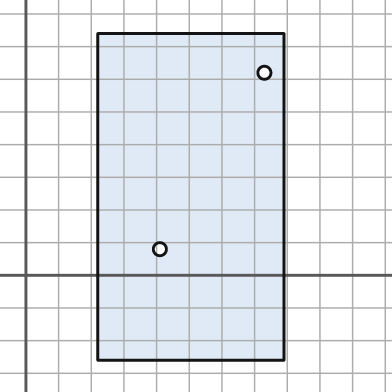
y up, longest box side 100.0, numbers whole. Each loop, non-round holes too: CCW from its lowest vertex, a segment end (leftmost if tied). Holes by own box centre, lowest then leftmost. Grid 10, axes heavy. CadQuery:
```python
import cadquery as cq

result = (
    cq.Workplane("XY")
    .moveTo(22.0, -26.0)
    .lineTo(79.0, -26.0)
    .lineTo(79.0, 74.0)
    .lineTo(22.0, 74.0)
    .close()
    .moveTo(41.0, 8.0)
    .circle(2.0)
    .moveTo(73.0, 62.0)
    .circle(2.0)
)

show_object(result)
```